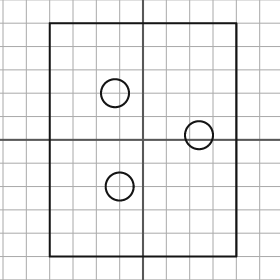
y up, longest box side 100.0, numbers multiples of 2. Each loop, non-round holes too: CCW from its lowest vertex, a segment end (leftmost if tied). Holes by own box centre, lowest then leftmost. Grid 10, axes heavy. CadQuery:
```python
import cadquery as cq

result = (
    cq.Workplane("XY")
    .moveTo(-40.0, -50.0)
    .lineTo(40.0, -50.0)
    .lineTo(40.0, 50.0)
    .lineTo(-40.0, 50.0)
    .close()
    .moveTo(-10.0, -20.0)
    .circle(6.0)
    .moveTo(24.0, 2.0)
    .circle(6.0)
    .moveTo(-12.0, 20.0)
    .circle(6.0)
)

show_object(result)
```